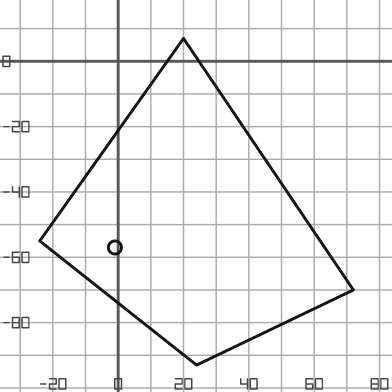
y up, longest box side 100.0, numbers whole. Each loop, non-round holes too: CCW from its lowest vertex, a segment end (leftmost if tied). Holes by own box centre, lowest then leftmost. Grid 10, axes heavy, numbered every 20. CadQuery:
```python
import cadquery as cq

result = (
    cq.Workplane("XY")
    .moveTo(24.0, -93.0)
    .lineTo(72.0, -70.0)
    .lineTo(20.0, 7.0)
    .lineTo(-24.0, -55.0)
    .close()
    .moveTo(-1.0, -57.0)
    .circle(2.0)
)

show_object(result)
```